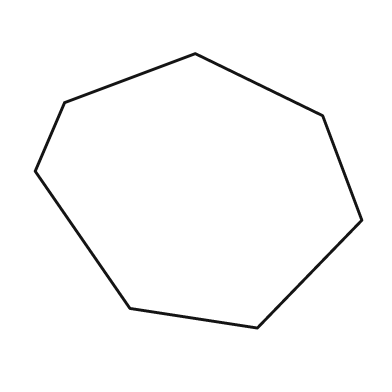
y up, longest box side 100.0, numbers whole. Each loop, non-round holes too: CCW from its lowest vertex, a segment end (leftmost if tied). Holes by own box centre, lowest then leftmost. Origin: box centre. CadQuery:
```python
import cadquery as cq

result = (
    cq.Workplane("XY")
    .moveTo(18.0, -42.0)
    .lineTo(50.0, -9.0)
    .lineTo(38.0, 23.0)
    .lineTo(-1.0, 42.0)
    .lineTo(-41.0, 27.0)
    .lineTo(-50.0, 6.0)
    .lineTo(-21.0, -36.0)
    .close()
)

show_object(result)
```